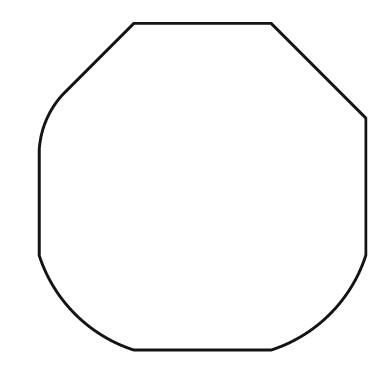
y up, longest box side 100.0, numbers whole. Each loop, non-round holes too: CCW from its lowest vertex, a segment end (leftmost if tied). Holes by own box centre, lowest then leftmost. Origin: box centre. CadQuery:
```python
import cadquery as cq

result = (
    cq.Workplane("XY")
    .moveTo(-21.0, -50.0)
    .lineTo(21.0, -50.0)
    .threePointArc((39.0, -39.0), (50.0, -21.0))
    .lineTo(50.0, 21.0)
    .lineTo(21.0, 50.0)
    .lineTo(-21.0, 50.0)
    .lineTo(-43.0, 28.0)
    .threePointArc((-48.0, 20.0), (-50.0, 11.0))
    .lineTo(-50.0, -21.0)
    .threePointArc((-39.0, -39.0), (-21.0, -50.0))
    .close()
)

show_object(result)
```